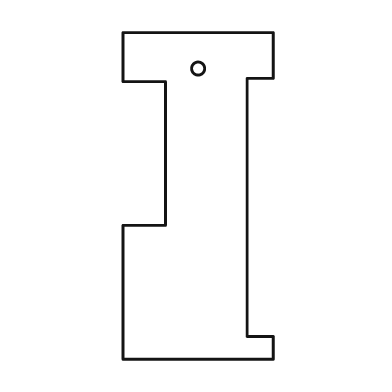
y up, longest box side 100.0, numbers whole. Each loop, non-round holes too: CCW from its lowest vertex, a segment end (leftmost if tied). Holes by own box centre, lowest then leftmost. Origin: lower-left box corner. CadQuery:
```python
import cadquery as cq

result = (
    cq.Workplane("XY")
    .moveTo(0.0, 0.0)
    .lineTo(46.0, 0.0)
    .lineTo(46.0, 7.0)
    .lineTo(38.0, 7.0)
    .lineTo(38.0, 86.0)
    .lineTo(46.0, 86.0)
    .lineTo(46.0, 100.0)
    .lineTo(0.0, 100.0)
    .lineTo(0.0, 85.0)
    .lineTo(13.0, 85.0)
    .lineTo(13.0, 41.0)
    .lineTo(0.0, 41.0)
    .close()
    .moveTo(23.0, 89.0)
    .circle(2.0)
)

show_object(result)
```